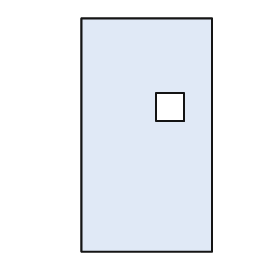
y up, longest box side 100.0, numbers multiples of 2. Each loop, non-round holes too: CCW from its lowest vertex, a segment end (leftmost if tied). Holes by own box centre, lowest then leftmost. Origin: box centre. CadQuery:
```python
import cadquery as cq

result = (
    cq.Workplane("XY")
    .moveTo(-28.0, -50.0)
    .lineTo(28.0, -50.0)
    .lineTo(28.0, 50.0)
    .lineTo(-28.0, 50.0)
    .close()
    .moveTo(4.0, 6.0)
    .lineTo(16.0, 6.0)
    .lineTo(16.0, 18.0)
    .lineTo(4.0, 18.0)
    .close()
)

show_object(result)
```